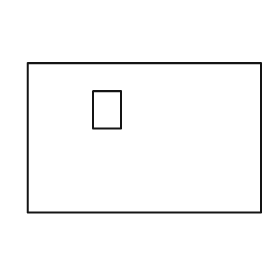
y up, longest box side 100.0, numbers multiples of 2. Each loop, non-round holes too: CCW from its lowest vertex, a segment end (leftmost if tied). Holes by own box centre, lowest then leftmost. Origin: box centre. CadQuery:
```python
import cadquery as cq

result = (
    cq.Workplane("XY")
    .moveTo(-50.0, -32.0)
    .lineTo(50.0, -32.0)
    .lineTo(50.0, 32.0)
    .lineTo(-50.0, 32.0)
    .close()
    .moveTo(-22.0, 4.0)
    .lineTo(-10.0, 4.0)
    .lineTo(-10.0, 20.0)
    .lineTo(-22.0, 20.0)
    .close()
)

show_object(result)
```